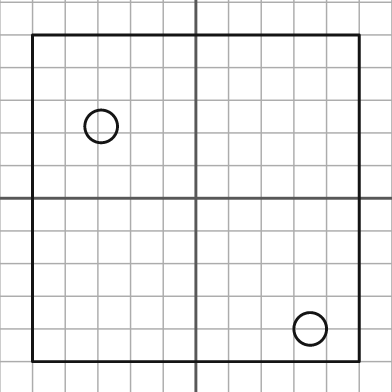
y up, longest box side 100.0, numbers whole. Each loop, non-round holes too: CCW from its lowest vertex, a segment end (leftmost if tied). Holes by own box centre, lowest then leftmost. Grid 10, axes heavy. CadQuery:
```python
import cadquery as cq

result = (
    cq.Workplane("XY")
    .moveTo(-50.0, -50.0)
    .lineTo(50.0, -50.0)
    .lineTo(50.0, 50.0)
    .lineTo(-50.0, 50.0)
    .close()
    .moveTo(35.0, -40.0)
    .circle(5.0)
    .moveTo(-29.0, 22.0)
    .circle(5.0)
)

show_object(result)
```